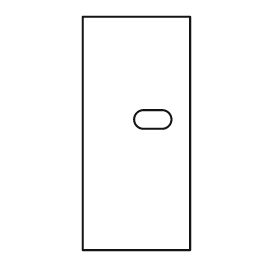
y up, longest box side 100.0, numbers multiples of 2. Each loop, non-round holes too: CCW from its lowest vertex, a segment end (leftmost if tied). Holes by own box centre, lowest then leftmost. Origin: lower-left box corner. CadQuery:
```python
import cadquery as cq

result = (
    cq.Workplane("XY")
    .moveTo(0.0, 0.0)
    .lineTo(46.0, 0.0)
    .lineTo(46.0, 100.0)
    .lineTo(0.0, 100.0)
    .close()
    .moveTo(26.0, 52.0)
    .lineTo(34.0, 52.0)
    .threePointArc((38.0, 56.0), (34.0, 60.0))
    .lineTo(26.0, 60.0)
    .threePointArc((22.0, 56.0), (26.0, 52.0))
    .close()
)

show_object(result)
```